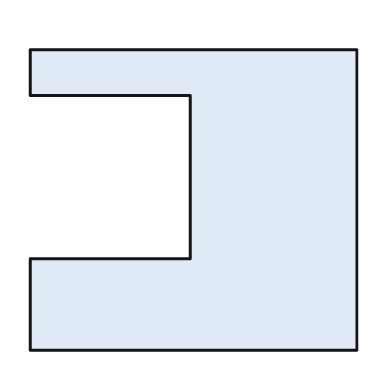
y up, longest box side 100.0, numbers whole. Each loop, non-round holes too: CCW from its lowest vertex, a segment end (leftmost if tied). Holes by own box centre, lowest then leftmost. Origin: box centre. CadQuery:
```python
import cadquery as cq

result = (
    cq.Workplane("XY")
    .moveTo(-50.0, -46.0)
    .lineTo(50.0, -46.0)
    .lineTo(50.0, 46.0)
    .lineTo(-50.0, 46.0)
    .lineTo(-50.0, 32.0)
    .lineTo(-1.0, 32.0)
    .lineTo(-1.0, -18.0)
    .lineTo(-50.0, -18.0)
    .close()
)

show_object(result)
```